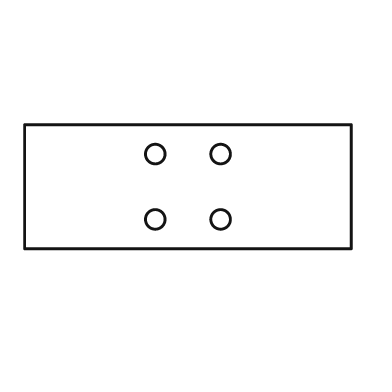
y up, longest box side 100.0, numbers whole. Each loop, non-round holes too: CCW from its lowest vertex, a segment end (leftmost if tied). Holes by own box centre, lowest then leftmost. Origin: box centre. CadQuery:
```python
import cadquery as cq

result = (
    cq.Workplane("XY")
    .moveTo(-50.0, -19.0)
    .lineTo(50.0, -19.0)
    .lineTo(50.0, 19.0)
    .lineTo(-50.0, 19.0)
    .close()
    .moveTo(-10.0, -10.0)
    .circle(3.0)
    .moveTo(10.0, -10.0)
    .circle(3.0)
    .moveTo(-10.0, 10.0)
    .circle(3.0)
    .moveTo(10.0, 10.0)
    .circle(3.0)
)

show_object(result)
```